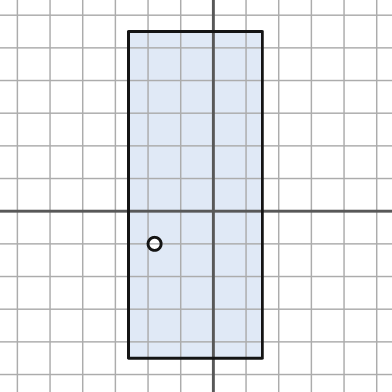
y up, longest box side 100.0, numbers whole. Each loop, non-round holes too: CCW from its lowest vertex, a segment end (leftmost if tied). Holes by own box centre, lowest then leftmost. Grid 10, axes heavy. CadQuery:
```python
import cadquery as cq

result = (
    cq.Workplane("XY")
    .moveTo(-26.0, -45.0)
    .lineTo(15.0, -45.0)
    .lineTo(15.0, 55.0)
    .lineTo(-26.0, 55.0)
    .close()
    .moveTo(-18.0, -10.0)
    .circle(2.0)
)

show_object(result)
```